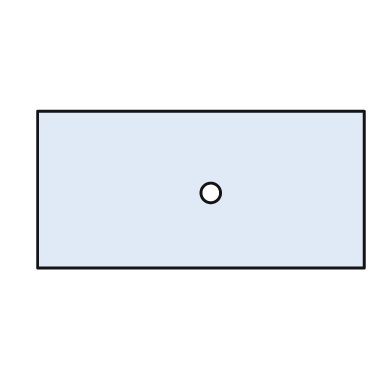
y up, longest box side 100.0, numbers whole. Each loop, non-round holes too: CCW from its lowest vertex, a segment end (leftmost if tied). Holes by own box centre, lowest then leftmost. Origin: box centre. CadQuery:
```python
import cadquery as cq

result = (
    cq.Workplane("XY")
    .moveTo(-50.0, -24.0)
    .lineTo(50.0, -24.0)
    .lineTo(50.0, 24.0)
    .lineTo(-50.0, 24.0)
    .close()
    .moveTo(3.0, -1.0)
    .circle(3.0)
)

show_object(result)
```